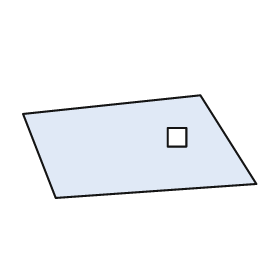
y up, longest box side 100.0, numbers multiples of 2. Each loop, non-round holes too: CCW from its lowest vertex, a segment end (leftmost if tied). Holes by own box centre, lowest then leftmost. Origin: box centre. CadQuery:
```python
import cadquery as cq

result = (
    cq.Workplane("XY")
    .moveTo(-36.0, -22.0)
    .lineTo(50.0, -16.0)
    .lineTo(26.0, 22.0)
    .lineTo(-50.0, 14.0)
    .close()
    .moveTo(12.0, 0.0)
    .lineTo(20.0, 0.0)
    .lineTo(20.0, 8.0)
    .lineTo(12.0, 8.0)
    .close()
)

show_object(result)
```